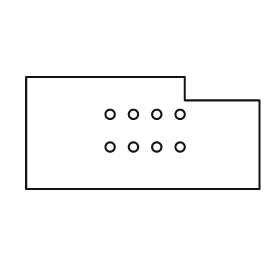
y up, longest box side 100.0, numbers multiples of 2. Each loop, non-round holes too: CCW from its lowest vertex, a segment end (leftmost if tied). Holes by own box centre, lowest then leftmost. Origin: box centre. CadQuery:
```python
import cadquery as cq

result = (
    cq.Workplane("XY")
    .moveTo(-50.0, -24.0)
    .lineTo(50.0, -24.0)
    .lineTo(50.0, 14.0)
    .lineTo(18.0, 14.0)
    .lineTo(18.0, 24.0)
    .lineTo(-50.0, 24.0)
    .close()
    .moveTo(-14.0, -6.0)
    .circle(2.0)
    .moveTo(-4.0, -6.0)
    .circle(2.0)
    .moveTo(6.0, -6.0)
    .circle(2.0)
    .moveTo(16.0, -6.0)
    .circle(2.0)
    .moveTo(-14.0, 8.0)
    .circle(2.0)
    .moveTo(-4.0, 8.0)
    .circle(2.0)
    .moveTo(6.0, 8.0)
    .circle(2.0)
    .moveTo(16.0, 8.0)
    .circle(2.0)
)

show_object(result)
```